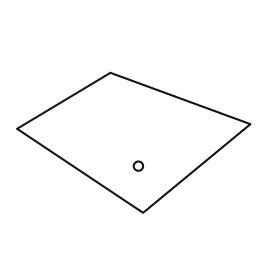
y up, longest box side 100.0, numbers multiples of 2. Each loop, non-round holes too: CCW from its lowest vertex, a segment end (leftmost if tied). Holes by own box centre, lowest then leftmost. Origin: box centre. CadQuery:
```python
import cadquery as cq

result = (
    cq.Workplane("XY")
    .moveTo(4.0, -30.0)
    .lineTo(50.0, 8.0)
    .lineTo(-10.0, 30.0)
    .lineTo(-50.0, 6.0)
    .close()
    .moveTo(2.0, -10.0)
    .circle(2.0)
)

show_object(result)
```